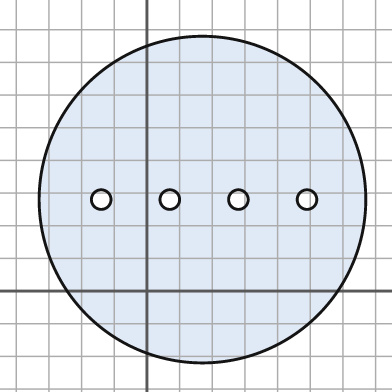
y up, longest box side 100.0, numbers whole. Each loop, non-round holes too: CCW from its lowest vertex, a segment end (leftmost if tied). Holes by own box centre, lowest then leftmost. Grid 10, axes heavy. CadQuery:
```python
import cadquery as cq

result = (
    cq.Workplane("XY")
    .moveTo(17.0, 28.0)
    .circle(50.0)
    .moveTo(-14.0, 28.0)
    .circle(3.0)
    .moveTo(7.0, 28.0)
    .circle(3.0)
    .moveTo(28.0, 28.0)
    .circle(3.0)
    .moveTo(49.0, 28.0)
    .circle(3.0)
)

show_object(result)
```